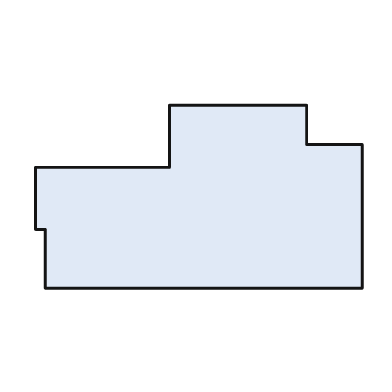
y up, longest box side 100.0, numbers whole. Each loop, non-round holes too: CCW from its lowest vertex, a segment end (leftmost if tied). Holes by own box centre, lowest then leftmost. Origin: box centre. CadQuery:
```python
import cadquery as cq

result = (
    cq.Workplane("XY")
    .moveTo(-47.0, -28.0)
    .lineTo(50.0, -28.0)
    .lineTo(50.0, 16.0)
    .lineTo(33.0, 16.0)
    .lineTo(33.0, 28.0)
    .lineTo(-9.0, 28.0)
    .lineTo(-9.0, 9.0)
    .lineTo(-50.0, 9.0)
    .lineTo(-50.0, -10.0)
    .lineTo(-47.0, -10.0)
    .close()
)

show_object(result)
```